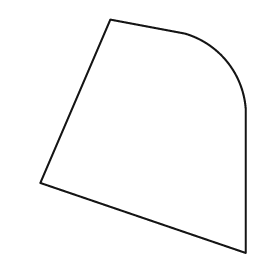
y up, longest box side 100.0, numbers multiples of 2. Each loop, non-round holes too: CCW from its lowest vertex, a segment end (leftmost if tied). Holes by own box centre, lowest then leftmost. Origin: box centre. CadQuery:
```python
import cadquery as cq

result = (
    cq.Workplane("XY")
    .moveTo(44.0, -50.0)
    .lineTo(44.0, 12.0)
    .threePointArc((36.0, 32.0), (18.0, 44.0))
    .lineTo(-14.0, 50.0)
    .lineTo(-44.0, -20.0)
    .close()
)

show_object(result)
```